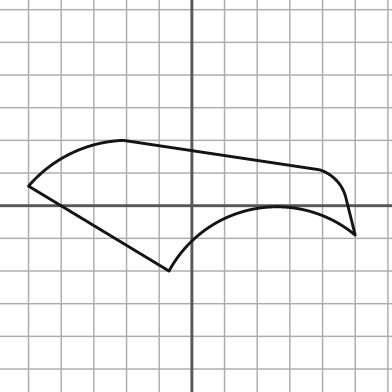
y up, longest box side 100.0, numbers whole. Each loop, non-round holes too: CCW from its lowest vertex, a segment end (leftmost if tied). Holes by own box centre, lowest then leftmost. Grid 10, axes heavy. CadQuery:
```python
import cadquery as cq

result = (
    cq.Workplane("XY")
    .moveTo(-7.0, -20.0)
    .threePointArc((19.0, -1.0), (50.0, -9.0))
    .lineTo(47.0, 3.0)
    .threePointArc((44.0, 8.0), (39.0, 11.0))
    .lineTo(-21.0, 20.0)
    .threePointArc((-37.0, 16.0), (-50.0, 6.0))
    .close()
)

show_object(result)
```